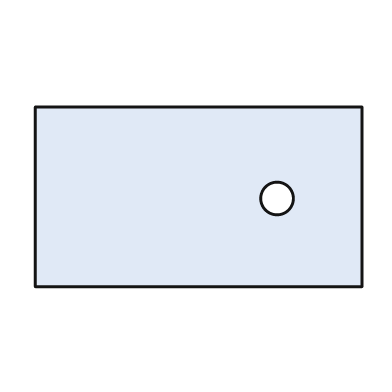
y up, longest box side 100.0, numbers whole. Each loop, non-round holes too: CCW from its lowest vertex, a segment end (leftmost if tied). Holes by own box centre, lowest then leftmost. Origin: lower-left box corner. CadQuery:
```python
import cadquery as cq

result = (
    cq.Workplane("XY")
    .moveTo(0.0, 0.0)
    .lineTo(100.0, 0.0)
    .lineTo(100.0, 55.0)
    .lineTo(0.0, 55.0)
    .close()
    .moveTo(74.0, 27.0)
    .circle(5.0)
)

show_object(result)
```